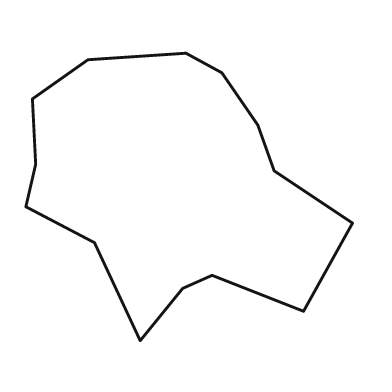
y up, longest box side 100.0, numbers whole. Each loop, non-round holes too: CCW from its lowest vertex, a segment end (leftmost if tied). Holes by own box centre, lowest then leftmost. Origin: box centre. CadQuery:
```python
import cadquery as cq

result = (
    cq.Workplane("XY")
    .moveTo(-15.0, -44.0)
    .lineTo(-2.0, -28.0)
    .lineTo(7.0, -24.0)
    .lineTo(35.0, -35.0)
    .lineTo(50.0, -8.0)
    .lineTo(26.0, 8.0)
    .lineTo(21.0, 22.0)
    .lineTo(10.0, 38.0)
    .lineTo(-1.0, 44.0)
    .lineTo(-31.0, 42.0)
    .lineTo(-48.0, 30.0)
    .lineTo(-47.0, 10.0)
    .lineTo(-50.0, -3.0)
    .lineTo(-29.0, -14.0)
    .close()
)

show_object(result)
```